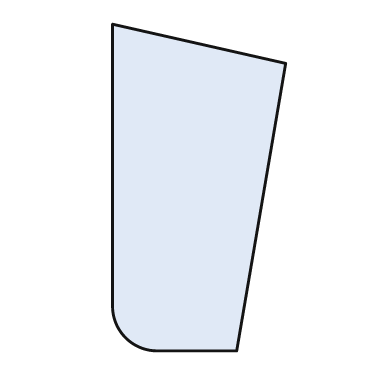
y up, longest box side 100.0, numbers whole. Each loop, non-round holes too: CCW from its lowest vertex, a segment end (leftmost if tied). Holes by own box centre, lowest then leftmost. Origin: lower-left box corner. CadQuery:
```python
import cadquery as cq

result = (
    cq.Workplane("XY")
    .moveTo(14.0, 0.0)
    .lineTo(38.0, 0.0)
    .lineTo(53.0, 88.0)
    .lineTo(0.0, 100.0)
    .lineTo(0.0, 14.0)
    .threePointArc((4.0, 4.0), (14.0, 0.0))
    .close()
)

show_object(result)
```